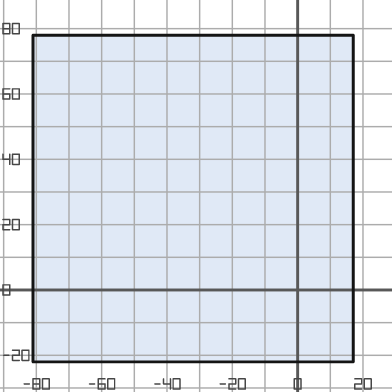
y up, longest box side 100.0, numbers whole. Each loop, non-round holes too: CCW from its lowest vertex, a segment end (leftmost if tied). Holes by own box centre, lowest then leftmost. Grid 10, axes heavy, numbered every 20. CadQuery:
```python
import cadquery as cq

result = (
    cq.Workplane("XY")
    .moveTo(-81.0, -22.0)
    .lineTo(17.0, -22.0)
    .lineTo(17.0, 78.0)
    .lineTo(-81.0, 78.0)
    .close()
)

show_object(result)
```